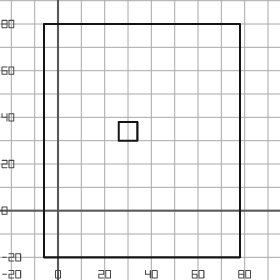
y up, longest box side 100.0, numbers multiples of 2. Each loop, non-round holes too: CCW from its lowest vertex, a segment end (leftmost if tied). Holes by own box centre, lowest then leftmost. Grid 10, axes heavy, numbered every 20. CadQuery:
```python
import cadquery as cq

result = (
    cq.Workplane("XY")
    .moveTo(-6.0, -20.0)
    .lineTo(78.0, -20.0)
    .lineTo(78.0, 80.0)
    .lineTo(-6.0, 80.0)
    .close()
    .moveTo(26.0, 30.0)
    .lineTo(34.0, 30.0)
    .lineTo(34.0, 38.0)
    .lineTo(26.0, 38.0)
    .close()
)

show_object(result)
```